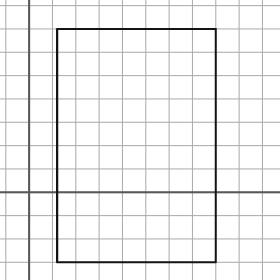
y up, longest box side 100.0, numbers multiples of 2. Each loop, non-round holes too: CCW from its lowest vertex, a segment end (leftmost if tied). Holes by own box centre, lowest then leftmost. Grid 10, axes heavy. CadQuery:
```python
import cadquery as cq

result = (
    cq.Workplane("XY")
    .moveTo(12.0, -30.0)
    .lineTo(80.0, -30.0)
    .lineTo(80.0, 70.0)
    .lineTo(12.0, 70.0)
    .close()
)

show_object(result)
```